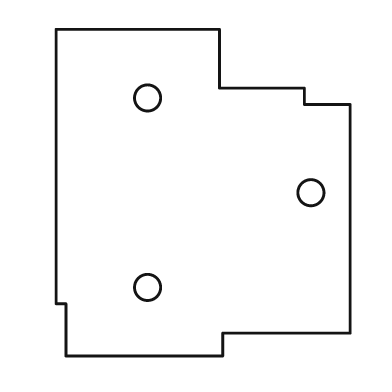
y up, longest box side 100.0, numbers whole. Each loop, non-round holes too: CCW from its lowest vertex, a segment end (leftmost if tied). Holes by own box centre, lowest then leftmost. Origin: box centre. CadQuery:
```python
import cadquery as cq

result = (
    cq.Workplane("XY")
    .moveTo(-42.0, -50.0)
    .lineTo(6.0, -50.0)
    .lineTo(6.0, -43.0)
    .lineTo(45.0, -43.0)
    .lineTo(45.0, 27.0)
    .lineTo(31.0, 27.0)
    .lineTo(31.0, 32.0)
    .lineTo(5.0, 32.0)
    .lineTo(5.0, 50.0)
    .lineTo(-45.0, 50.0)
    .lineTo(-45.0, -34.0)
    .lineTo(-42.0, -34.0)
    .close()
    .moveTo(-17.0, -29.0)
    .circle(4.0)
    .moveTo(33.0, 0.0)
    .circle(4.0)
    .moveTo(-17.0, 29.0)
    .circle(4.0)
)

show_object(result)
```